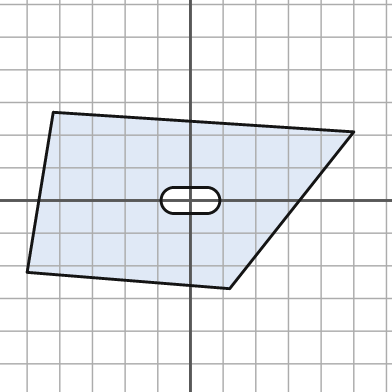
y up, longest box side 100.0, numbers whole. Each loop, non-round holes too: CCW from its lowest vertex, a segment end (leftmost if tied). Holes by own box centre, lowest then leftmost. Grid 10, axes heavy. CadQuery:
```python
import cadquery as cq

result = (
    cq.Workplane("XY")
    .moveTo(12.0, -27.0)
    .lineTo(50.0, 21.0)
    .lineTo(-42.0, 27.0)
    .lineTo(-50.0, -22.0)
    .close()
    .moveTo(-5.0, -4.0)
    .lineTo(5.0, -4.0)
    .threePointArc((9.0, 0.0), (5.0, 4.0))
    .lineTo(-5.0, 4.0)
    .threePointArc((-9.0, 0.0), (-5.0, -4.0))
    .close()
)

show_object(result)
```